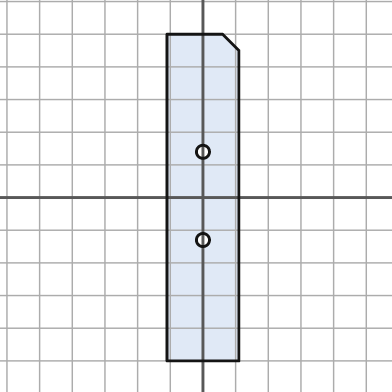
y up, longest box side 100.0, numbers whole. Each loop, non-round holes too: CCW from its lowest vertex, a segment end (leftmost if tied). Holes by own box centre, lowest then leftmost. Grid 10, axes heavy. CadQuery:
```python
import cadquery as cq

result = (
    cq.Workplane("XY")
    .moveTo(-11.0, -50.0)
    .lineTo(11.0, -50.0)
    .lineTo(11.0, 45.0)
    .lineTo(6.0, 50.0)
    .lineTo(-11.0, 50.0)
    .close()
    .moveTo(0.0, -13.0)
    .circle(2.0)
    .moveTo(0.0, 14.0)
    .circle(2.0)
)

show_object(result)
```